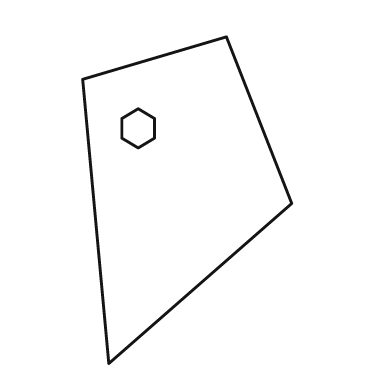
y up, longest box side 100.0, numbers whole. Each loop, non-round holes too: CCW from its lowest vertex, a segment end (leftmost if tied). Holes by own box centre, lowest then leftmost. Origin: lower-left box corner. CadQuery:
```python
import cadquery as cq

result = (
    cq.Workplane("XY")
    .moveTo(8.0, 0.0)
    .lineTo(64.0, 49.0)
    .lineTo(44.0, 100.0)
    .lineTo(0.0, 87.0)
    .close()
    .moveTo(17.0, 66.0)
    .lineTo(22.0, 69.0)
    .lineTo(22.0, 75.0)
    .lineTo(17.0, 78.0)
    .lineTo(12.0, 75.0)
    .lineTo(12.0, 69.0)
    .close()
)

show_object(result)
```